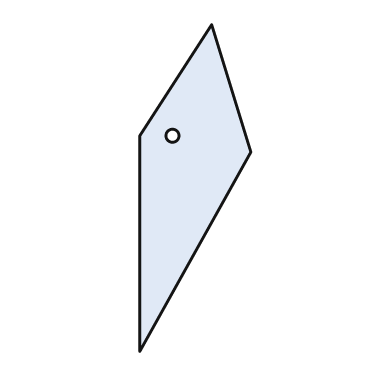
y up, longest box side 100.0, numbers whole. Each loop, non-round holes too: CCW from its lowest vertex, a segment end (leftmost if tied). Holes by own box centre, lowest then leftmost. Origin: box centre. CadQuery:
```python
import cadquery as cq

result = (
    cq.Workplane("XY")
    .moveTo(-17.0, -50.0)
    .lineTo(17.0, 11.0)
    .lineTo(5.0, 50.0)
    .lineTo(-17.0, 16.0)
    .close()
    .moveTo(-7.0, 16.0)
    .circle(2.0)
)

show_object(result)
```